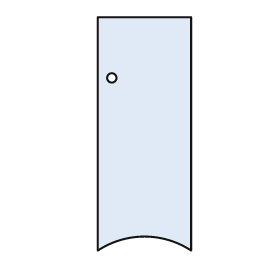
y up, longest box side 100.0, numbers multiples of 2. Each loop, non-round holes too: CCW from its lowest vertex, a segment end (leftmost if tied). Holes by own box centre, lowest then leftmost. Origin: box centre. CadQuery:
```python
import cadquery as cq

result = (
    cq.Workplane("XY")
    .moveTo(-20.0, -50.0)
    .threePointArc((0.0, -44.0), (20.0, -50.0))
    .lineTo(20.0, 50.0)
    .lineTo(-20.0, 50.0)
    .close()
    .moveTo(-14.0, 24.0)
    .circle(2.0)
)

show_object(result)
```